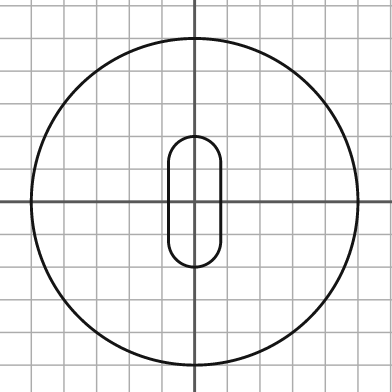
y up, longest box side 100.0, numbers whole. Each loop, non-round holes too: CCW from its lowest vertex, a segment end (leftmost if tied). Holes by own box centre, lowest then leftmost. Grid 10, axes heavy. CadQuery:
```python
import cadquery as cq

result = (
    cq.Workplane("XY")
    .moveTo(0.0, 0.0)
    .circle(50.0)
    .moveTo(-8.0, -12.0)
    .threePointArc((0.0, -20.0), (8.0, -12.0))
    .lineTo(8.0, 12.0)
    .threePointArc((0.0, 20.0), (-8.0, 12.0))
    .close()
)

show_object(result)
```